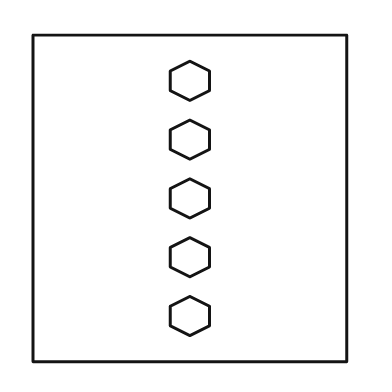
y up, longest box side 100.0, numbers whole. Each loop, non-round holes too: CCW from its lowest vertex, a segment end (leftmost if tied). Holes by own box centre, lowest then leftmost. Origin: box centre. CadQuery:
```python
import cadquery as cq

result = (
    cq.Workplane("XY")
    .moveTo(-48.0, -50.0)
    .lineTo(48.0, -50.0)
    .lineTo(48.0, 50.0)
    .lineTo(-48.0, 50.0)
    .close()
    .moveTo(0.0, -42.0)
    .lineTo(6.0, -39.0)
    .lineTo(6.0, -33.0)
    .lineTo(0.0, -30.0)
    .lineTo(-6.0, -33.0)
    .lineTo(-6.0, -39.0)
    .close()
    .moveTo(0.0, -24.0)
    .lineTo(6.0, -21.0)
    .lineTo(6.0, -15.0)
    .lineTo(0.0, -12.0)
    .lineTo(-6.0, -15.0)
    .lineTo(-6.0, -21.0)
    .close()
    .moveTo(0.0, -6.0)
    .lineTo(6.0, -3.0)
    .lineTo(6.0, 3.0)
    .lineTo(0.0, 6.0)
    .lineTo(-6.0, 3.0)
    .lineTo(-6.0, -3.0)
    .close()
    .moveTo(0.0, 12.0)
    .lineTo(6.0, 15.0)
    .lineTo(6.0, 21.0)
    .lineTo(0.0, 24.0)
    .lineTo(-6.0, 21.0)
    .lineTo(-6.0, 15.0)
    .close()
    .moveTo(0.0, 30.0)
    .lineTo(6.0, 33.0)
    .lineTo(6.0, 39.0)
    .lineTo(0.0, 42.0)
    .lineTo(-6.0, 39.0)
    .lineTo(-6.0, 33.0)
    .close()
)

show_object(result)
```